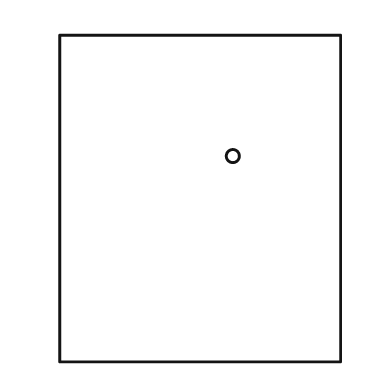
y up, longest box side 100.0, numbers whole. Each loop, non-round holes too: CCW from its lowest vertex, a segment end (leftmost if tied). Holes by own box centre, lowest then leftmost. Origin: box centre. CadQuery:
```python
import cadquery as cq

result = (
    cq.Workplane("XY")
    .moveTo(-43.0, -50.0)
    .lineTo(43.0, -50.0)
    .lineTo(43.0, 50.0)
    .lineTo(-43.0, 50.0)
    .close()
    .moveTo(10.0, 13.0)
    .circle(2.0)
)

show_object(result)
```